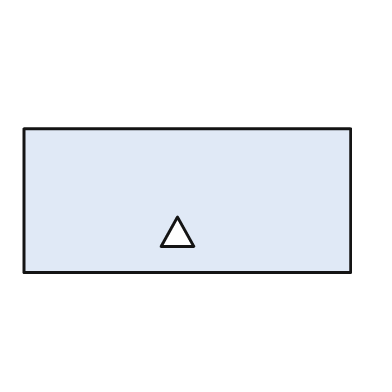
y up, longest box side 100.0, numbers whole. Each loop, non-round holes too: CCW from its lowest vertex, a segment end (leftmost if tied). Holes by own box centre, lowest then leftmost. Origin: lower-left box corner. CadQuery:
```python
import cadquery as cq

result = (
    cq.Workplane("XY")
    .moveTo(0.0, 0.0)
    .lineTo(100.0, 0.0)
    .lineTo(100.0, 44.0)
    .lineTo(0.0, 44.0)
    .close()
    .moveTo(42.0, 8.0)
    .lineTo(52.0, 8.0)
    .lineTo(47.0, 17.0)
    .close()
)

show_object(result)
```